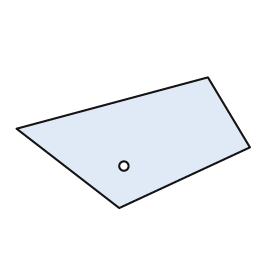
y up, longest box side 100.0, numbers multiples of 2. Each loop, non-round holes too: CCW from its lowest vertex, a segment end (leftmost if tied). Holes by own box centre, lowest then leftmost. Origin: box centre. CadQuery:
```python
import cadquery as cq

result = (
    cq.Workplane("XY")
    .moveTo(-6.0, -28.0)
    .lineTo(50.0, -2.0)
    .lineTo(32.0, 28.0)
    .lineTo(-50.0, 6.0)
    .close()
    .moveTo(-4.0, -10.0)
    .circle(2.0)
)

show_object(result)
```